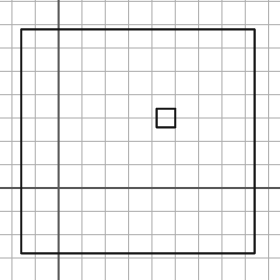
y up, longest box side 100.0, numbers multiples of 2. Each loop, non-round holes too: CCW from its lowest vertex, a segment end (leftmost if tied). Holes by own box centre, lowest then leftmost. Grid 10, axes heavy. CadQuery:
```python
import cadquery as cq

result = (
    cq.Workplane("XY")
    .moveTo(-16.0, -28.0)
    .lineTo(84.0, -28.0)
    .lineTo(84.0, 68.0)
    .lineTo(-16.0, 68.0)
    .close()
    .moveTo(42.0, 26.0)
    .lineTo(50.0, 26.0)
    .lineTo(50.0, 34.0)
    .lineTo(42.0, 34.0)
    .close()
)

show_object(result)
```